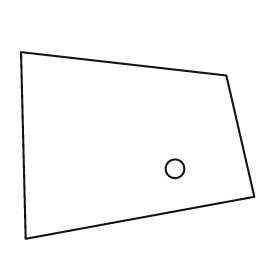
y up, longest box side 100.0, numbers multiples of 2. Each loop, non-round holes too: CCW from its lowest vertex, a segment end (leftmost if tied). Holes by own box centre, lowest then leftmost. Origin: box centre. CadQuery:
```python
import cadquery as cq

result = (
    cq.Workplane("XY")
    .moveTo(-48.0, -40.0)
    .lineTo(50.0, -22.0)
    .lineTo(38.0, 30.0)
    .lineTo(-50.0, 40.0)
    .close()
    .moveTo(16.0, -10.0)
    .circle(4.0)
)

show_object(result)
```